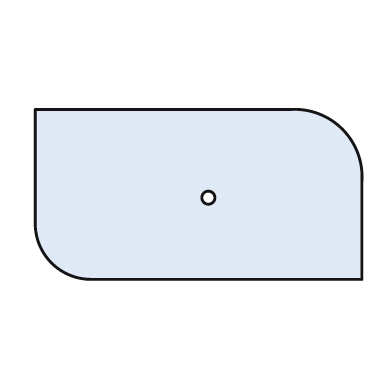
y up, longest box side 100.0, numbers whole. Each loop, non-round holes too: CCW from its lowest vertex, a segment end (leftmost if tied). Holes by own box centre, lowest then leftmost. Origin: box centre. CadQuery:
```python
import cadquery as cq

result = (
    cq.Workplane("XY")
    .moveTo(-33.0, -26.0)
    .lineTo(50.0, -26.0)
    .lineTo(50.0, 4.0)
    .threePointArc((44.0, 20.0), (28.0, 26.0))
    .lineTo(-50.0, 26.0)
    .lineTo(-50.0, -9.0)
    .threePointArc((-45.0, -21.0), (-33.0, -26.0))
    .close()
    .moveTo(3.0, -1.0)
    .circle(2.0)
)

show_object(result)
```